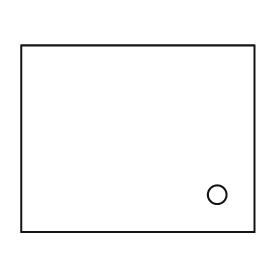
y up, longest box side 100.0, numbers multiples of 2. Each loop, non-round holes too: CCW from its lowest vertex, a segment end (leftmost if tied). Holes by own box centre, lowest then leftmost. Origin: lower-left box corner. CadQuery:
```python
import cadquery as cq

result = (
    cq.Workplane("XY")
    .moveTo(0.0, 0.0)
    .lineTo(100.0, 0.0)
    .lineTo(100.0, 80.0)
    .lineTo(0.0, 80.0)
    .close()
    .moveTo(84.0, 16.0)
    .circle(4.0)
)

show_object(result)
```